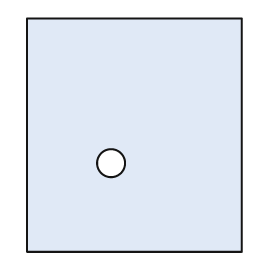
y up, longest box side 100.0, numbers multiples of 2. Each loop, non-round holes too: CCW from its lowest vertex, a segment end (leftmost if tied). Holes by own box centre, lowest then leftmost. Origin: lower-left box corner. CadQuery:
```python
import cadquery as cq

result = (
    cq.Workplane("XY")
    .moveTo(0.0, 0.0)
    .lineTo(92.0, 0.0)
    .lineTo(92.0, 100.0)
    .lineTo(0.0, 100.0)
    .close()
    .moveTo(36.0, 38.0)
    .circle(6.0)
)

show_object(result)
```